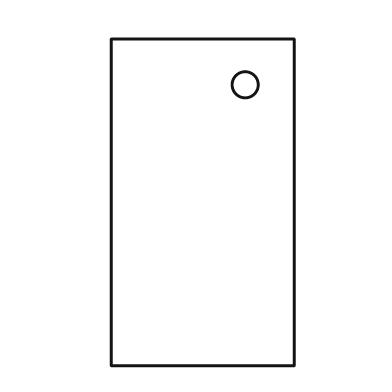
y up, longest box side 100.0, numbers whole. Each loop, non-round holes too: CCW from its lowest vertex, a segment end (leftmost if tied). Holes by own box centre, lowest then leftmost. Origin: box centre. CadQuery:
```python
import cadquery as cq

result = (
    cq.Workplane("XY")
    .moveTo(-28.0, -50.0)
    .lineTo(28.0, -50.0)
    .lineTo(28.0, 50.0)
    .lineTo(-28.0, 50.0)
    .close()
    .moveTo(13.0, 36.0)
    .circle(4.0)
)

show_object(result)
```